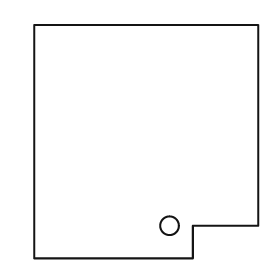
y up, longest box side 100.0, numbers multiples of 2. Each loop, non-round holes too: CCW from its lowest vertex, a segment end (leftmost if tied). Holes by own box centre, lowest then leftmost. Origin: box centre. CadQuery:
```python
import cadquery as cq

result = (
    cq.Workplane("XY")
    .moveTo(-48.0, -50.0)
    .lineTo(20.0, -50.0)
    .lineTo(20.0, -36.0)
    .lineTo(48.0, -36.0)
    .lineTo(48.0, 50.0)
    .lineTo(-48.0, 50.0)
    .close()
    .moveTo(10.0, -36.0)
    .circle(4.0)
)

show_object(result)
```